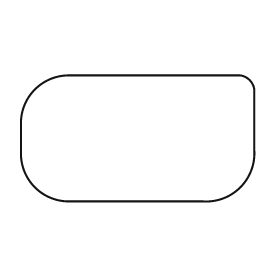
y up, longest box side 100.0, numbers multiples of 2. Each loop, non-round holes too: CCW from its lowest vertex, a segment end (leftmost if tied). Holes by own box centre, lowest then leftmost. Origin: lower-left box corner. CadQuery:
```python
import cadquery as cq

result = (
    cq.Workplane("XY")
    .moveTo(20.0, 0.0)
    .lineTo(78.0, 0.0)
    .threePointArc((94.0, 6.0), (100.0, 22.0))
    .lineTo(100.0, 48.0)
    .threePointArc((98.0, 52.0), (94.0, 54.0))
    .lineTo(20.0, 54.0)
    .threePointArc((6.0, 48.0), (0.0, 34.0))
    .lineTo(0.0, 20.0)
    .threePointArc((6.0, 6.0), (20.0, 0.0))
    .close()
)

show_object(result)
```